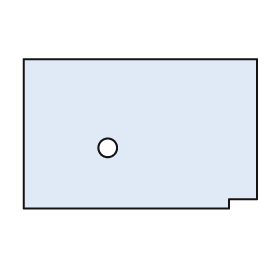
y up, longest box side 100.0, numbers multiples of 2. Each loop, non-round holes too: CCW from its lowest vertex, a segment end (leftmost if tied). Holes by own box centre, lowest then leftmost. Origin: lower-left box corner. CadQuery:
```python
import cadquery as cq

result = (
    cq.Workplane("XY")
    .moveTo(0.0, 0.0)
    .lineTo(88.0, 0.0)
    .lineTo(88.0, 4.0)
    .lineTo(100.0, 4.0)
    .lineTo(100.0, 64.0)
    .lineTo(0.0, 64.0)
    .close()
    .moveTo(36.0, 26.0)
    .circle(4.0)
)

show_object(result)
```